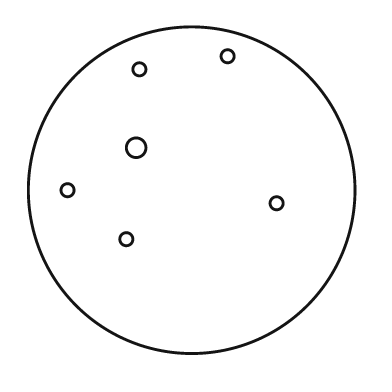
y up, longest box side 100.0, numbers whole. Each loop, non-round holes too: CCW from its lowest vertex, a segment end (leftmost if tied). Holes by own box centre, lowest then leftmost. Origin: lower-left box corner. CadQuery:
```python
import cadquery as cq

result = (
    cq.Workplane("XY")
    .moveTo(50.0, 50.0)
    .circle(50.0)
    .moveTo(30.0, 35.0)
    .circle(2.0)
    .moveTo(76.0, 46.0)
    .circle(2.0)
    .moveTo(12.0, 50.0)
    .circle(2.0)
    .moveTo(33.0, 63.0)
    .circle(3.0)
    .moveTo(34.0, 87.0)
    .circle(2.0)
    .moveTo(61.0, 91.0)
    .circle(2.0)
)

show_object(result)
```